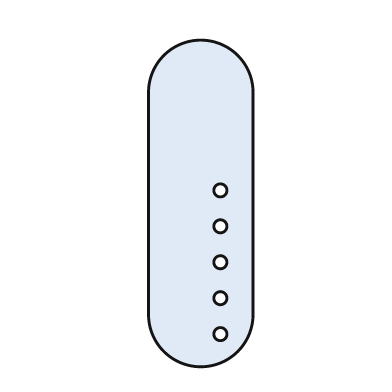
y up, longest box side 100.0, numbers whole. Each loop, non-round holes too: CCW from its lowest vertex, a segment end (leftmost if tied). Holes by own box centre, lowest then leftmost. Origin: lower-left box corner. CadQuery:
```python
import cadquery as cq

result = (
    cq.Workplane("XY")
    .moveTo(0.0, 16.0)
    .threePointArc((16.0, 0.0), (32.0, 16.0))
    .lineTo(32.0, 84.0)
    .threePointArc((16.0, 100.0), (0.0, 84.0))
    .close()
    .moveTo(22.0, 10.0)
    .circle(2.0)
    .moveTo(22.0, 21.0)
    .circle(2.0)
    .moveTo(22.0, 32.0)
    .circle(2.0)
    .moveTo(22.0, 43.0)
    .circle(2.0)
    .moveTo(22.0, 54.0)
    .circle(2.0)
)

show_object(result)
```